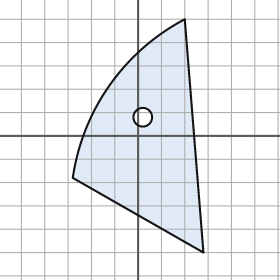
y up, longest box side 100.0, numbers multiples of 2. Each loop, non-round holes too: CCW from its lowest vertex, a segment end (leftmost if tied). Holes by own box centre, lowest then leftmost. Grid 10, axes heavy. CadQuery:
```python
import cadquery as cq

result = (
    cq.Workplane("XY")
    .moveTo(28.0, -50.0)
    .lineTo(20.0, 50.0)
    .threePointArc((-12.0, 22.0), (-28.0, -18.0))
    .close()
    .moveTo(2.0, 8.0)
    .circle(4.0)
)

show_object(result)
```